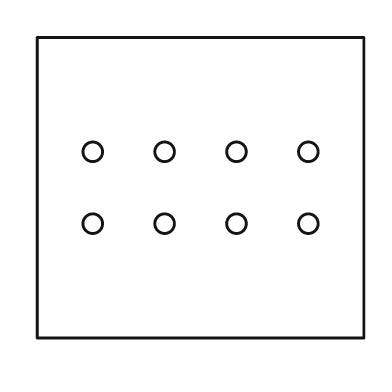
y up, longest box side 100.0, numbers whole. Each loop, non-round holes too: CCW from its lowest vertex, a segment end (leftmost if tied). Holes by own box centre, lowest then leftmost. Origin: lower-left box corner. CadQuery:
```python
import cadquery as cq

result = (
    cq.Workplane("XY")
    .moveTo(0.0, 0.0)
    .lineTo(100.0, 0.0)
    .lineTo(100.0, 92.0)
    .lineTo(0.0, 92.0)
    .close()
    .moveTo(17.0, 35.0)
    .circle(3.0)
    .moveTo(39.0, 35.0)
    .circle(3.0)
    .moveTo(61.0, 35.0)
    .circle(3.0)
    .moveTo(83.0, 35.0)
    .circle(3.0)
    .moveTo(17.0, 57.0)
    .circle(3.0)
    .moveTo(39.0, 57.0)
    .circle(3.0)
    .moveTo(61.0, 57.0)
    .circle(3.0)
    .moveTo(83.0, 57.0)
    .circle(3.0)
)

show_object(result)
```